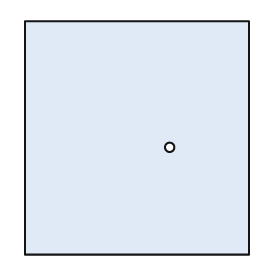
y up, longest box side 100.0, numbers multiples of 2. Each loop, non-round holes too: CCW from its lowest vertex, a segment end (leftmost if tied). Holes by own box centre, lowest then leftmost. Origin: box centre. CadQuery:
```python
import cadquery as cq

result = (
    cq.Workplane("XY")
    .moveTo(-48.0, -50.0)
    .lineTo(48.0, -50.0)
    .lineTo(48.0, 50.0)
    .lineTo(-48.0, 50.0)
    .close()
    .moveTo(14.0, -4.0)
    .circle(2.0)
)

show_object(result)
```